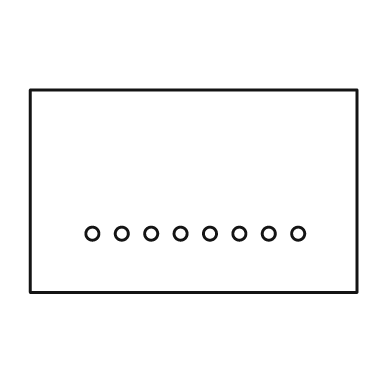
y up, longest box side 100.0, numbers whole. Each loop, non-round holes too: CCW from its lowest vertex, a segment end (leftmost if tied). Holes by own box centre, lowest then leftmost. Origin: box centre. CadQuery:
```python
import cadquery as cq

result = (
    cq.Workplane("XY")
    .moveTo(-50.0, -31.0)
    .lineTo(50.0, -31.0)
    .lineTo(50.0, 31.0)
    .lineTo(-50.0, 31.0)
    .close()
    .moveTo(-31.0, -13.0)
    .circle(2.0)
    .moveTo(-22.0, -13.0)
    .circle(2.0)
    .moveTo(-13.0, -13.0)
    .circle(2.0)
    .moveTo(-4.0, -13.0)
    .circle(2.0)
    .moveTo(5.0, -13.0)
    .circle(2.0)
    .moveTo(14.0, -13.0)
    .circle(2.0)
    .moveTo(23.0, -13.0)
    .circle(2.0)
    .moveTo(32.0, -13.0)
    .circle(2.0)
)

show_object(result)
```